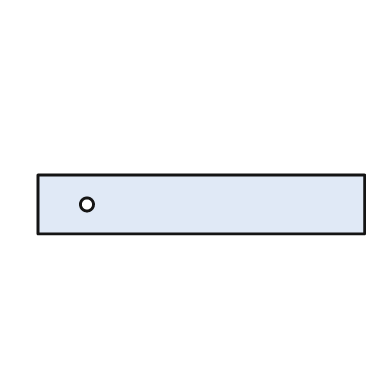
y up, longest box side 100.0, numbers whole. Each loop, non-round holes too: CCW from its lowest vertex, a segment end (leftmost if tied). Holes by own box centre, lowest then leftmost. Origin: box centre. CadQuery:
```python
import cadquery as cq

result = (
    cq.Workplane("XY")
    .moveTo(-50.0, -9.0)
    .lineTo(50.0, -9.0)
    .lineTo(50.0, 9.0)
    .lineTo(-50.0, 9.0)
    .close()
    .moveTo(-35.0, 0.0)
    .circle(2.0)
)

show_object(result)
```